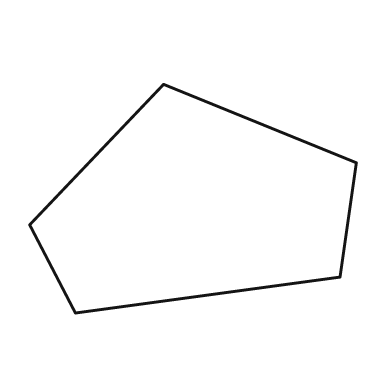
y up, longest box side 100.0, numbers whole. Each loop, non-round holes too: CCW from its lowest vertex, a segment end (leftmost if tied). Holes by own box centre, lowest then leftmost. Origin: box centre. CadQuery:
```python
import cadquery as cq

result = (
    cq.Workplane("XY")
    .moveTo(-36.0, -35.0)
    .lineTo(45.0, -24.0)
    .lineTo(50.0, 11.0)
    .lineTo(-9.0, 35.0)
    .lineTo(-50.0, -8.0)
    .close()
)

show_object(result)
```